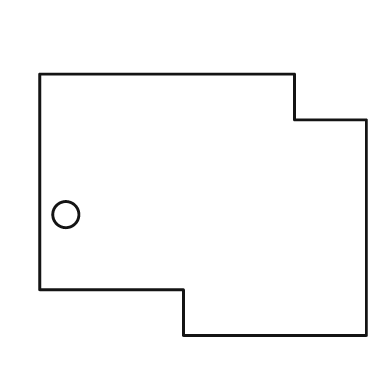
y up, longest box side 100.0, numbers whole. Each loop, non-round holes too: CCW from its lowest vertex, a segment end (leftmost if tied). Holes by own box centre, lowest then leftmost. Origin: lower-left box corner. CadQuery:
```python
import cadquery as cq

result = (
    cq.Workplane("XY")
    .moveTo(44.0, 0.0)
    .lineTo(100.0, 0.0)
    .lineTo(100.0, 66.0)
    .lineTo(78.0, 66.0)
    .lineTo(78.0, 80.0)
    .lineTo(0.0, 80.0)
    .lineTo(0.0, 14.0)
    .lineTo(44.0, 14.0)
    .close()
    .moveTo(8.0, 37.0)
    .circle(4.0)
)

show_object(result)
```